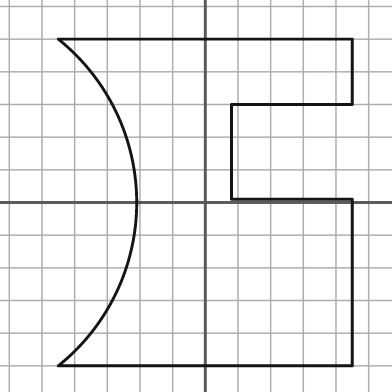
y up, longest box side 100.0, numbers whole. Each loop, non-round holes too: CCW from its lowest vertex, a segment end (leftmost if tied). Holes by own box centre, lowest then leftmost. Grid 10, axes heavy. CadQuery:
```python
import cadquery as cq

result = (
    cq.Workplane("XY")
    .moveTo(-45.0, -50.0)
    .lineTo(45.0, -50.0)
    .lineTo(45.0, 1.0)
    .lineTo(8.0, 1.0)
    .lineTo(8.0, 30.0)
    .lineTo(45.0, 30.0)
    .lineTo(45.0, 50.0)
    .lineTo(-45.0, 50.0)
    .threePointArc((-21.0, 0.0), (-45.0, -50.0))
    .close()
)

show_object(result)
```